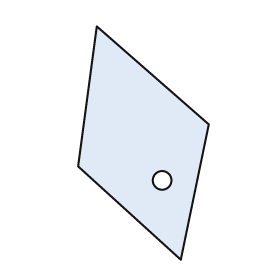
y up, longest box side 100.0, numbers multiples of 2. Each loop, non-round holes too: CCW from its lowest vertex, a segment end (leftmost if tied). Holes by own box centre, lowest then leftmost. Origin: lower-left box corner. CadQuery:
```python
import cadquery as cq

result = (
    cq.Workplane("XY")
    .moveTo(44.0, 0.0)
    .lineTo(56.0, 58.0)
    .lineTo(8.0, 100.0)
    .lineTo(0.0, 40.0)
    .close()
    .moveTo(36.0, 34.0)
    .circle(4.0)
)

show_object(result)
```